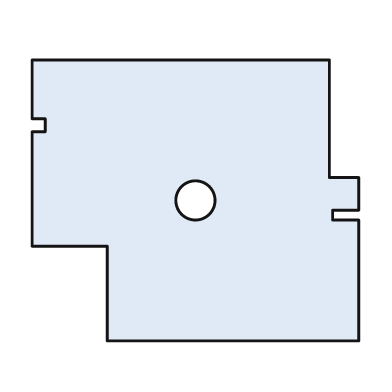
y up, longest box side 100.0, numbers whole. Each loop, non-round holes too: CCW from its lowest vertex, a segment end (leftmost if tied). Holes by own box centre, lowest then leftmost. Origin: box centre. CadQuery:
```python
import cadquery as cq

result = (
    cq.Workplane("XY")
    .moveTo(-27.0, -43.0)
    .lineTo(50.0, -43.0)
    .lineTo(50.0, -6.0)
    .lineTo(42.0, -6.0)
    .lineTo(42.0, -3.0)
    .lineTo(50.0, -3.0)
    .lineTo(50.0, 7.0)
    .lineTo(41.0, 7.0)
    .lineTo(41.0, 43.0)
    .lineTo(-50.0, 43.0)
    .lineTo(-50.0, 25.0)
    .lineTo(-46.0, 25.0)
    .lineTo(-46.0, 21.0)
    .lineTo(-50.0, 21.0)
    .lineTo(-50.0, -14.0)
    .lineTo(-27.0, -14.0)
    .close()
    .moveTo(0.0, 0.0)
    .circle(6.0)
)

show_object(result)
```